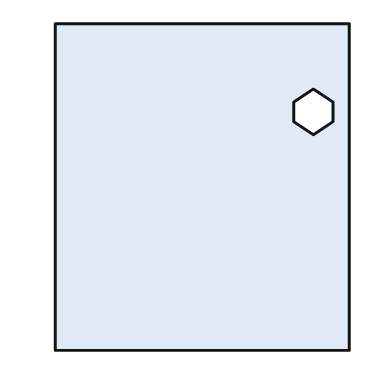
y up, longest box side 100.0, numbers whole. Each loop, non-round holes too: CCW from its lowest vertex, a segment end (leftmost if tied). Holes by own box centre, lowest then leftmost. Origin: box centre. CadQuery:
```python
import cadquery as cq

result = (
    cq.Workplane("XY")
    .moveTo(-45.0, -50.0)
    .lineTo(45.0, -50.0)
    .lineTo(45.0, 50.0)
    .lineTo(-45.0, 50.0)
    .close()
    .moveTo(34.0, 16.0)
    .lineTo(40.0, 20.0)
    .lineTo(40.0, 26.0)
    .lineTo(34.0, 30.0)
    .lineTo(28.0, 26.0)
    .lineTo(28.0, 20.0)
    .close()
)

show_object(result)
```